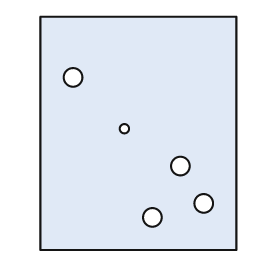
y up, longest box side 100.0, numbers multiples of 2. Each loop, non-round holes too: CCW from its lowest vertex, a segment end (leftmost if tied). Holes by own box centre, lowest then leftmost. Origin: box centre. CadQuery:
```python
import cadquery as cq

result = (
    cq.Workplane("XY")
    .moveTo(-42.0, -50.0)
    .lineTo(42.0, -50.0)
    .lineTo(42.0, 50.0)
    .lineTo(-42.0, 50.0)
    .close()
    .moveTo(6.0, -36.0)
    .circle(4.0)
    .moveTo(28.0, -30.0)
    .circle(4.0)
    .moveTo(18.0, -14.0)
    .circle(4.0)
    .moveTo(-6.0, 2.0)
    .circle(2.0)
    .moveTo(-28.0, 24.0)
    .circle(4.0)
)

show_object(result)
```